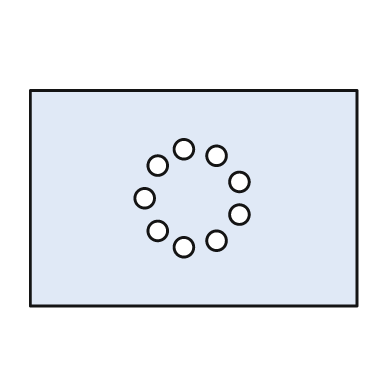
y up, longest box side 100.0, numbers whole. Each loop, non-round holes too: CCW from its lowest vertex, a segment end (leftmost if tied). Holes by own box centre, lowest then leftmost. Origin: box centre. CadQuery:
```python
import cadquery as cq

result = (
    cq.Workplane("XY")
    .moveTo(-50.0, -33.0)
    .lineTo(50.0, -33.0)
    .lineTo(50.0, 33.0)
    .lineTo(-50.0, 33.0)
    .close()
    .moveTo(-3.0, -15.0)
    .circle(3.0)
    .moveTo(7.0, -13.0)
    .circle(3.0)
    .moveTo(-11.0, -10.0)
    .circle(3.0)
    .moveTo(14.0, -5.0)
    .circle(3.0)
    .moveTo(-15.0, 0.0)
    .circle(3.0)
    .moveTo(14.0, 5.0)
    .circle(3.0)
    .moveTo(-11.0, 10.0)
    .circle(3.0)
    .moveTo(7.0, 13.0)
    .circle(3.0)
    .moveTo(-3.0, 15.0)
    .circle(3.0)
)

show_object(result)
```